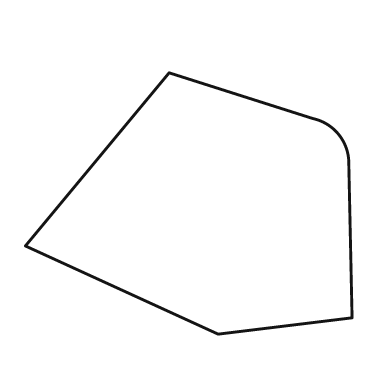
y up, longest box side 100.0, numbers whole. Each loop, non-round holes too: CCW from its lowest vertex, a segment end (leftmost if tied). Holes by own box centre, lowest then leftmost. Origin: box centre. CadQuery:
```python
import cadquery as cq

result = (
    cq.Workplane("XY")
    .moveTo(9.0, -40.0)
    .lineTo(50.0, -35.0)
    .lineTo(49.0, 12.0)
    .threePointArc((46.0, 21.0), (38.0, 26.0))
    .lineTo(-6.0, 40.0)
    .lineTo(-50.0, -13.0)
    .close()
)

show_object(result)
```